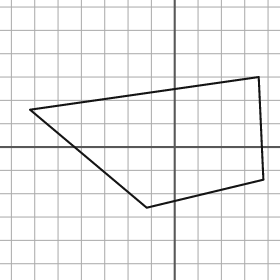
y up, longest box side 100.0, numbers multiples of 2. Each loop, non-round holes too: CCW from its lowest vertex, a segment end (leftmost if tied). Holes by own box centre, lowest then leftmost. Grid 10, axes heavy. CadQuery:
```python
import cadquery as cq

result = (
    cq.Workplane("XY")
    .moveTo(-12.0, -26.0)
    .lineTo(38.0, -14.0)
    .lineTo(36.0, 30.0)
    .lineTo(-62.0, 16.0)
    .close()
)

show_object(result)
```